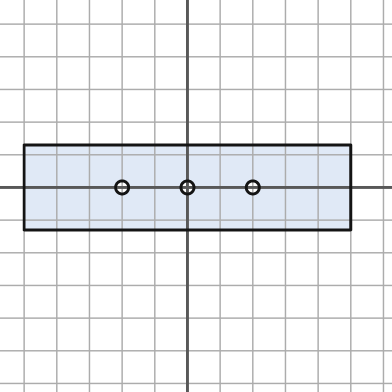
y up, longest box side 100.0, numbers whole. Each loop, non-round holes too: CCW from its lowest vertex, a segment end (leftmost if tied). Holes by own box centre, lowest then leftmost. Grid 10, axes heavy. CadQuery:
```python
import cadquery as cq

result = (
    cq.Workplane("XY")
    .moveTo(-50.0, -13.0)
    .lineTo(50.0, -13.0)
    .lineTo(50.0, 13.0)
    .lineTo(-50.0, 13.0)
    .close()
    .moveTo(-20.0, 0.0)
    .circle(2.0)
    .moveTo(0.0, 0.0)
    .circle(2.0)
    .moveTo(20.0, 0.0)
    .circle(2.0)
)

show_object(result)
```